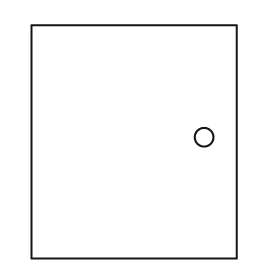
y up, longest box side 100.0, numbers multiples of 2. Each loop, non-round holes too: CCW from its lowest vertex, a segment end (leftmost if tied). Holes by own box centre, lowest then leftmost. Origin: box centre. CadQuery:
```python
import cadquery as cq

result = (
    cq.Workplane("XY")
    .moveTo(-44.0, -50.0)
    .lineTo(44.0, -50.0)
    .lineTo(44.0, 50.0)
    .lineTo(-44.0, 50.0)
    .close()
    .moveTo(30.0, 2.0)
    .circle(4.0)
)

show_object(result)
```